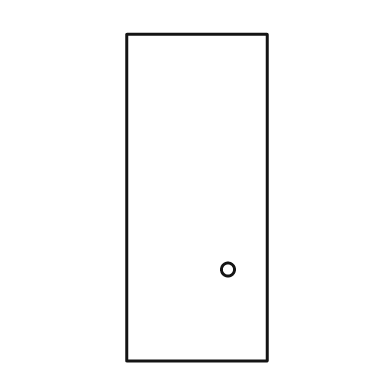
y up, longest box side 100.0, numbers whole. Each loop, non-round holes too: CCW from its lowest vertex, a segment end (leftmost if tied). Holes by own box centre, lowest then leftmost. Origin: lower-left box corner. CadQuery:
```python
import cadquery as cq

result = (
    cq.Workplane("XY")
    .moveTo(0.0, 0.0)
    .lineTo(43.0, 0.0)
    .lineTo(43.0, 100.0)
    .lineTo(0.0, 100.0)
    .close()
    .moveTo(31.0, 28.0)
    .circle(2.0)
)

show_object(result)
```